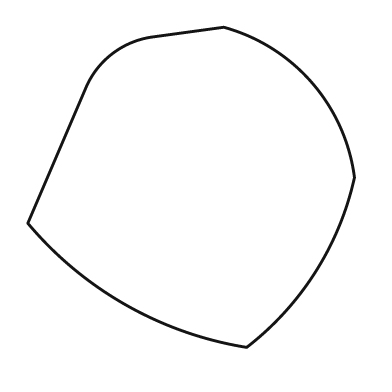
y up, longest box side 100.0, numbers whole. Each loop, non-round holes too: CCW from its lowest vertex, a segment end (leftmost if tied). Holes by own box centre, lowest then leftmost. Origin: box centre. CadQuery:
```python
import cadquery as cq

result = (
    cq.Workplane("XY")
    .moveTo(17.0, -49.0)
    .threePointArc((38.0, -26.0), (50.0, 3.0))
    .threePointArc((37.0, 32.0), (10.0, 49.0))
    .lineTo(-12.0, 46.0)
    .threePointArc((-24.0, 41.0), (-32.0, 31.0))
    .lineTo(-50.0, -11.0)
    .threePointArc((-20.0, -36.0), (17.0, -49.0))
    .close()
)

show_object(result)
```